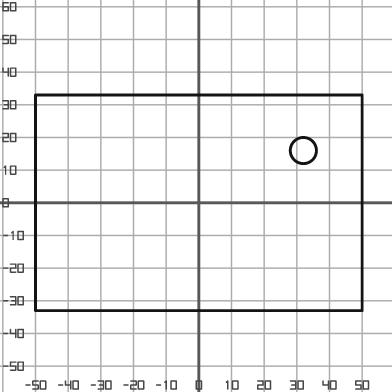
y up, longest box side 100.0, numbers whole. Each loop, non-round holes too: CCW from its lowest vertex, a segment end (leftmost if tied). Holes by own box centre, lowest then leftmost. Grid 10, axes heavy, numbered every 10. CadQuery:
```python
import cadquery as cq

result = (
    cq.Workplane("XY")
    .moveTo(-50.0, -33.0)
    .lineTo(50.0, -33.0)
    .lineTo(50.0, 33.0)
    .lineTo(-50.0, 33.0)
    .close()
    .moveTo(32.0, 16.0)
    .circle(4.0)
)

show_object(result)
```